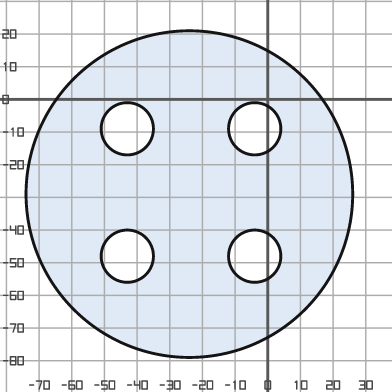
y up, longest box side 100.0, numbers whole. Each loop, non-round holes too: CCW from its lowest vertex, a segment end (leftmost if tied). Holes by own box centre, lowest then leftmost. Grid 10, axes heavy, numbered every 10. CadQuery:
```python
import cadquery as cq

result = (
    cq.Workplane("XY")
    .moveTo(-24.0, -29.0)
    .circle(50.0)
    .moveTo(-43.0, -48.0)
    .circle(8.0)
    .moveTo(-4.0, -48.0)
    .circle(8.0)
    .moveTo(-43.0, -9.0)
    .circle(8.0)
    .moveTo(-4.0, -9.0)
    .circle(8.0)
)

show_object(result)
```